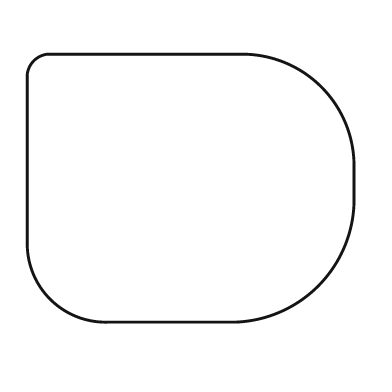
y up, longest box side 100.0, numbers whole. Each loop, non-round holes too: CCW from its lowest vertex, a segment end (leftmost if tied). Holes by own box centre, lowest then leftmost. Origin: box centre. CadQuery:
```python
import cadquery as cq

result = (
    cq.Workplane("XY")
    .moveTo(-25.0, -41.0)
    .lineTo(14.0, -41.0)
    .threePointArc((39.0, -30.0), (50.0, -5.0))
    .lineTo(50.0, 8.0)
    .threePointArc((40.0, 31.0), (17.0, 41.0))
    .lineTo(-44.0, 41.0)
    .threePointArc((-48.0, 39.0), (-50.0, 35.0))
    .lineTo(-50.0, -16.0)
    .threePointArc((-43.0, -34.0), (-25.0, -41.0))
    .close()
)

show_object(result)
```